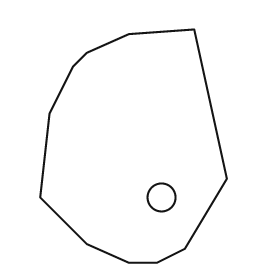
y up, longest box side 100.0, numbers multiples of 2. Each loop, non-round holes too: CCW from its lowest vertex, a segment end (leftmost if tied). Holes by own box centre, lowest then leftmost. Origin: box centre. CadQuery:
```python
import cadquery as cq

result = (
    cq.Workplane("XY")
    .moveTo(-2.0, -50.0)
    .lineTo(10.0, -50.0)
    .lineTo(22.0, -44.0)
    .lineTo(40.0, -14.0)
    .lineTo(26.0, 50.0)
    .lineTo(-2.0, 48.0)
    .lineTo(-20.0, 40.0)
    .lineTo(-26.0, 34.0)
    .lineTo(-36.0, 14.0)
    .lineTo(-40.0, -22.0)
    .lineTo(-20.0, -42.0)
    .close()
    .moveTo(12.0, -22.0)
    .circle(6.0)
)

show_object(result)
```